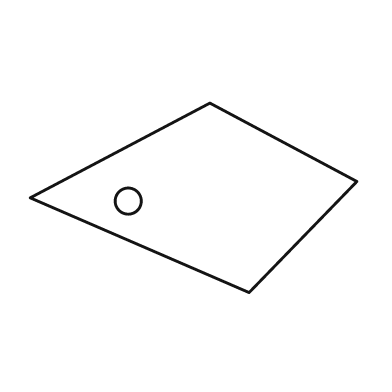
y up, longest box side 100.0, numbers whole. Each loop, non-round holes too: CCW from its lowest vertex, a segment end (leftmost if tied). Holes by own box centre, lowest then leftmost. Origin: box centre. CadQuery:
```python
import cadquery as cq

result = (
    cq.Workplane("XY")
    .moveTo(17.0, -29.0)
    .lineTo(50.0, 5.0)
    .lineTo(5.0, 29.0)
    .lineTo(-50.0, 0.0)
    .close()
    .moveTo(-20.0, -1.0)
    .circle(4.0)
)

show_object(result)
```